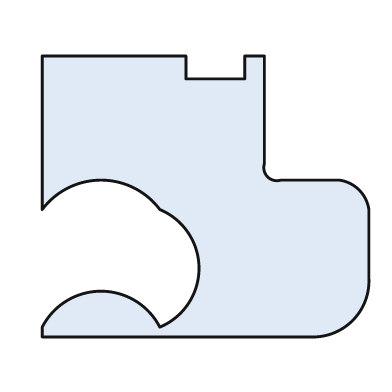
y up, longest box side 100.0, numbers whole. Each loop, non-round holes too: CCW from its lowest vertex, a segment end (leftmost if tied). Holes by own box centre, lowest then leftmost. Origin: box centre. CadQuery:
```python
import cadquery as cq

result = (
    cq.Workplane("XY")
    .moveTo(-50.0, -43.0)
    .lineTo(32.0, -43.0)
    .threePointArc((45.0, -38.0), (50.0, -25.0))
    .lineTo(50.0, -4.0)
    .threePointArc((47.0, 2.0), (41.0, 5.0))
    .lineTo(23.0, 5.0)
    .threePointArc((19.0, 6.0), (18.0, 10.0))
    .lineTo(18.0, 43.0)
    .lineTo(12.0, 43.0)
    .lineTo(12.0, 36.0)
    .lineTo(-6.0, 36.0)
    .lineTo(-6.0, 43.0)
    .lineTo(-50.0, 43.0)
    .lineTo(-50.0, -4.0)
    .threePointArc((-32.0, 5.0), (-14.0, -4.0))
    .threePointArc((-2.0, -22.0), (-14.0, -40.0))
    .threePointArc((-32.0, -29.0), (-50.0, -40.0))
    .close()
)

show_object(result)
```